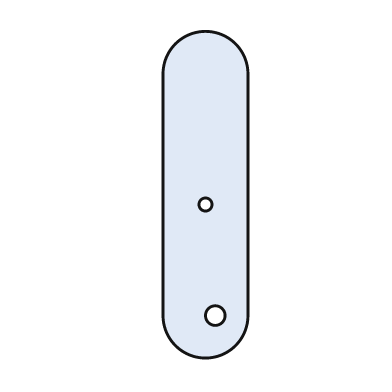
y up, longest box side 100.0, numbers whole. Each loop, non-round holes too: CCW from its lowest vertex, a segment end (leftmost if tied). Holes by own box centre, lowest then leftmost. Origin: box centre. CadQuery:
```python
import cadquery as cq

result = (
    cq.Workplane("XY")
    .moveTo(-13.0, -37.0)
    .threePointArc((0.0, -50.0), (13.0, -37.0))
    .lineTo(13.0, 37.0)
    .threePointArc((0.0, 50.0), (-13.0, 37.0))
    .close()
    .moveTo(3.0, -37.0)
    .circle(3.0)
    .moveTo(0.0, -3.0)
    .circle(2.0)
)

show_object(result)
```